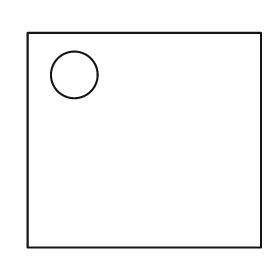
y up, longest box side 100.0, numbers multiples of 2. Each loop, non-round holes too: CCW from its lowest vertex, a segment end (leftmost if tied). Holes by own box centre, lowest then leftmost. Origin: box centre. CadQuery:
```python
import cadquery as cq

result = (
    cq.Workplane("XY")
    .moveTo(-50.0, -46.0)
    .lineTo(50.0, -46.0)
    .lineTo(50.0, 46.0)
    .lineTo(-50.0, 46.0)
    .close()
    .moveTo(-30.0, 28.0)
    .circle(10.0)
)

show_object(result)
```